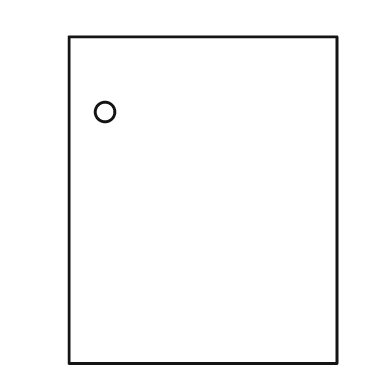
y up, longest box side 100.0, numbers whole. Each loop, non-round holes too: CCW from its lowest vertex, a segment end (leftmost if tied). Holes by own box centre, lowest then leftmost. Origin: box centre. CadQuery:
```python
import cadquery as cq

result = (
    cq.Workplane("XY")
    .moveTo(-41.0, -50.0)
    .lineTo(41.0, -50.0)
    .lineTo(41.0, 50.0)
    .lineTo(-41.0, 50.0)
    .close()
    .moveTo(-30.0, 27.0)
    .circle(3.0)
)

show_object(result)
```